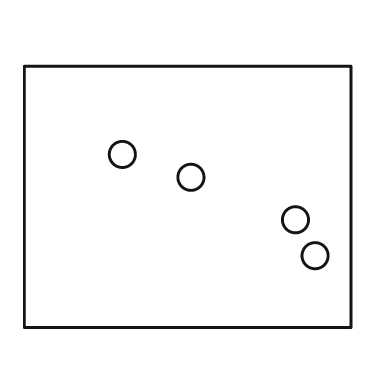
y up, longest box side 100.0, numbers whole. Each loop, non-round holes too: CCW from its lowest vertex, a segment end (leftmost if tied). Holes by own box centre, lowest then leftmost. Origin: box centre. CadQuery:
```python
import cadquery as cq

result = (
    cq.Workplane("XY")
    .moveTo(-50.0, -40.0)
    .lineTo(50.0, -40.0)
    .lineTo(50.0, 40.0)
    .lineTo(-50.0, 40.0)
    .close()
    .moveTo(39.0, -18.0)
    .circle(4.0)
    .moveTo(33.0, -7.0)
    .circle(4.0)
    .moveTo(1.0, 6.0)
    .circle(4.0)
    .moveTo(-20.0, 13.0)
    .circle(4.0)
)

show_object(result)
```